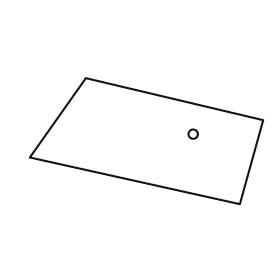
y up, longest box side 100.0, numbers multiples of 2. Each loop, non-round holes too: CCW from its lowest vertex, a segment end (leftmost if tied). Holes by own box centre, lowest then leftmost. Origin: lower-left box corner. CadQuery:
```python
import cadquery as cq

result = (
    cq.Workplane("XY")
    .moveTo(90.0, 0.0)
    .lineTo(100.0, 36.0)
    .lineTo(24.0, 54.0)
    .lineTo(0.0, 20.0)
    .close()
    .moveTo(70.0, 30.0)
    .circle(2.0)
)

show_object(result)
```